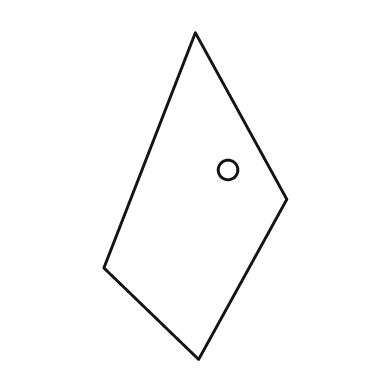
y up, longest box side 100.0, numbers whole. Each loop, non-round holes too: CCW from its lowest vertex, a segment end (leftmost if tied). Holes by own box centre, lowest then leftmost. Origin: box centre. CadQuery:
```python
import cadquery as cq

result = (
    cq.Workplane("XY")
    .moveTo(1.0, -50.0)
    .lineTo(28.0, -1.0)
    .lineTo(0.0, 50.0)
    .lineTo(-28.0, -22.0)
    .close()
    .moveTo(10.0, 8.0)
    .circle(3.0)
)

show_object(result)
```